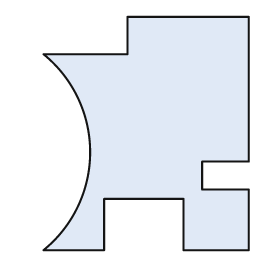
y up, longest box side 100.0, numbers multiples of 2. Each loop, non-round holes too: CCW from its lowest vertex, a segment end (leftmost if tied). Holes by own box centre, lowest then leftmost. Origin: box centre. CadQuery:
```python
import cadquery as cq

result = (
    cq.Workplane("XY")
    .moveTo(-44.0, -50.0)
    .lineTo(-18.0, -50.0)
    .lineTo(-18.0, -28.0)
    .lineTo(16.0, -28.0)
    .lineTo(16.0, -50.0)
    .lineTo(44.0, -50.0)
    .lineTo(44.0, -24.0)
    .lineTo(24.0, -24.0)
    .lineTo(24.0, -12.0)
    .lineTo(44.0, -12.0)
    .lineTo(44.0, 50.0)
    .lineTo(-8.0, 50.0)
    .lineTo(-8.0, 34.0)
    .lineTo(-44.0, 34.0)
    .threePointArc((-24.0, -8.0), (-44.0, -50.0))
    .close()
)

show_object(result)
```